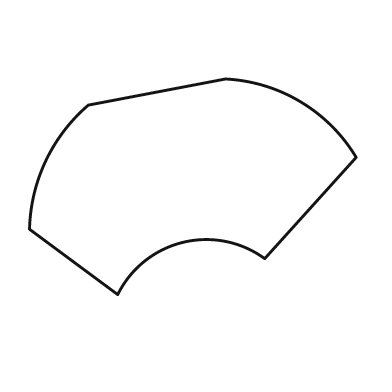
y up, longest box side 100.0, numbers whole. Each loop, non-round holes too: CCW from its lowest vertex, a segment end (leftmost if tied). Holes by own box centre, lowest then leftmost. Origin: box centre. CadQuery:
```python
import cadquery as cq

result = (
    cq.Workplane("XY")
    .moveTo(-23.0, -33.0)
    .threePointArc((-3.0, -17.0), (22.0, -22.0))
    .lineTo(50.0, 9.0)
    .threePointArc((33.0, 26.0), (10.0, 33.0))
    .lineTo(-32.0, 25.0)
    .threePointArc((-45.0, 8.0), (-50.0, -13.0))
    .close()
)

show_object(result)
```